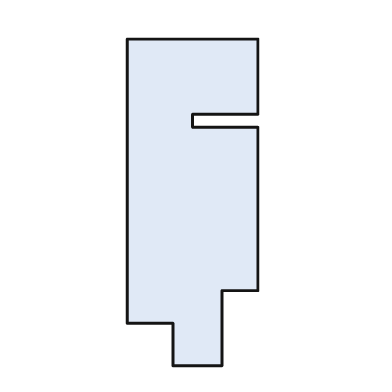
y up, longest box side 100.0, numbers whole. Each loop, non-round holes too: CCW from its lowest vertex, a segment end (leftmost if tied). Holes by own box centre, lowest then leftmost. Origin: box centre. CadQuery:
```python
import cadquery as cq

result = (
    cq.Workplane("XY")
    .moveTo(-6.0, -50.0)
    .lineTo(9.0, -50.0)
    .lineTo(9.0, -27.0)
    .lineTo(20.0, -27.0)
    .lineTo(20.0, 23.0)
    .lineTo(0.0, 23.0)
    .lineTo(0.0, 27.0)
    .lineTo(20.0, 27.0)
    .lineTo(20.0, 50.0)
    .lineTo(-20.0, 50.0)
    .lineTo(-20.0, -37.0)
    .lineTo(-6.0, -37.0)
    .close()
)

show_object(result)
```